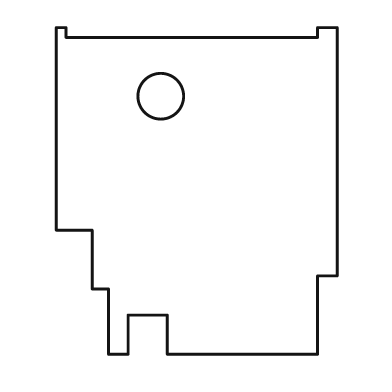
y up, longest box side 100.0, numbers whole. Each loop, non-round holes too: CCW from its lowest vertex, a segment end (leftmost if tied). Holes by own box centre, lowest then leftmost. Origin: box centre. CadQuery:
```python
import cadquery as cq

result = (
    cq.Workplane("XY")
    .moveTo(-27.0, -50.0)
    .lineTo(-21.0, -50.0)
    .lineTo(-21.0, -38.0)
    .lineTo(-9.0, -38.0)
    .lineTo(-9.0, -50.0)
    .lineTo(37.0, -50.0)
    .lineTo(37.0, -26.0)
    .lineTo(43.0, -26.0)
    .lineTo(43.0, 50.0)
    .lineTo(37.0, 50.0)
    .lineTo(37.0, 47.0)
    .lineTo(-40.0, 47.0)
    .lineTo(-40.0, 50.0)
    .lineTo(-43.0, 50.0)
    .lineTo(-43.0, -12.0)
    .lineTo(-32.0, -12.0)
    .lineTo(-32.0, -30.0)
    .lineTo(-27.0, -30.0)
    .close()
    .moveTo(-11.0, 29.0)
    .circle(7.0)
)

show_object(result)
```